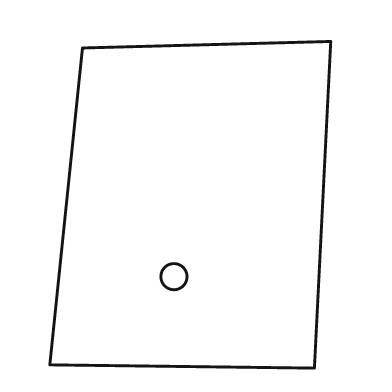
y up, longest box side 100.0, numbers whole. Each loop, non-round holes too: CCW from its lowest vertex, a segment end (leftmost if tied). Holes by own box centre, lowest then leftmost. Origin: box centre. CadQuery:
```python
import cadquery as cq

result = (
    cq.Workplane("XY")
    .moveTo(38.0, -50.0)
    .lineTo(43.0, 50.0)
    .lineTo(-33.0, 48.0)
    .lineTo(-43.0, -49.0)
    .close()
    .moveTo(-5.0, -22.0)
    .circle(4.0)
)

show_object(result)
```